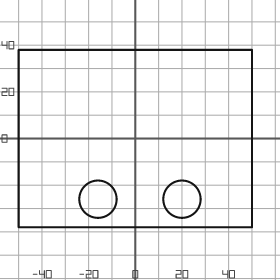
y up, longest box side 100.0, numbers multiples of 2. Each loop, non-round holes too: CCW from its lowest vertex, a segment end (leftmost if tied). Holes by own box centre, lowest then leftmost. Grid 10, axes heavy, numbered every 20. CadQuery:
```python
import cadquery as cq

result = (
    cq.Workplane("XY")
    .moveTo(-50.0, -38.0)
    .lineTo(50.0, -38.0)
    .lineTo(50.0, 38.0)
    .lineTo(-50.0, 38.0)
    .close()
    .moveTo(-16.0, -26.0)
    .circle(8.0)
    .moveTo(20.0, -26.0)
    .circle(8.0)
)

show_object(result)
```